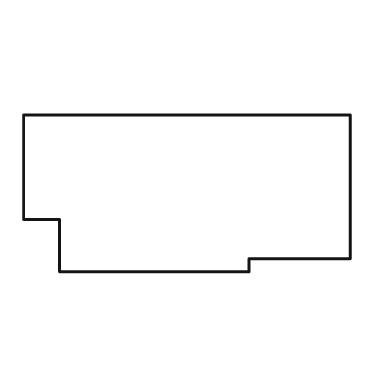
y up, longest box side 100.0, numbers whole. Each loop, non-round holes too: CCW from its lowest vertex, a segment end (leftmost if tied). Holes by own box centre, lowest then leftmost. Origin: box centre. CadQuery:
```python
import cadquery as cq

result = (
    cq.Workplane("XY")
    .moveTo(-39.0, -24.0)
    .lineTo(19.0, -24.0)
    .lineTo(19.0, -20.0)
    .lineTo(50.0, -20.0)
    .lineTo(50.0, 24.0)
    .lineTo(-50.0, 24.0)
    .lineTo(-50.0, -8.0)
    .lineTo(-39.0, -8.0)
    .close()
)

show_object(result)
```